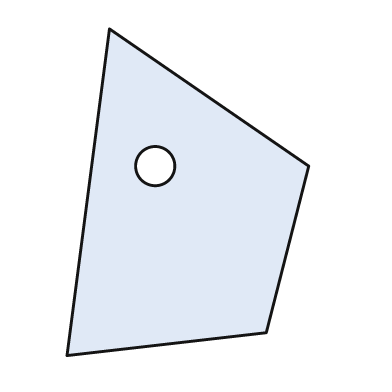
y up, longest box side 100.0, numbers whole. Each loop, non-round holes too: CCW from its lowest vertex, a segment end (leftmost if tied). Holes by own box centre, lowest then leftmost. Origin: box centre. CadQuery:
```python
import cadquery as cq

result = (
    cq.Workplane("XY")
    .moveTo(-37.0, -50.0)
    .lineTo(24.0, -43.0)
    .lineTo(37.0, 8.0)
    .lineTo(-24.0, 50.0)
    .close()
    .moveTo(-10.0, 8.0)
    .circle(6.0)
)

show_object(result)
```